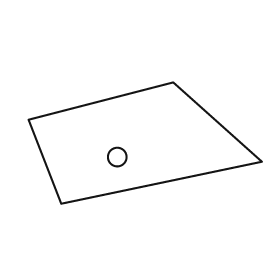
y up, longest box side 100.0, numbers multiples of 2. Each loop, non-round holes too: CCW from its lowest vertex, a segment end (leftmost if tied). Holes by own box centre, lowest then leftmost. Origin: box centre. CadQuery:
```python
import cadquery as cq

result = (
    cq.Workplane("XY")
    .moveTo(-36.0, -26.0)
    .lineTo(50.0, -8.0)
    .lineTo(12.0, 26.0)
    .lineTo(-50.0, 10.0)
    .close()
    .moveTo(-12.0, -6.0)
    .circle(4.0)
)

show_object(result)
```